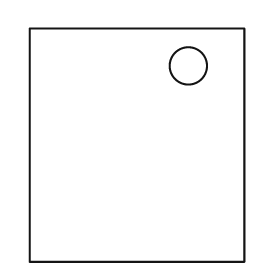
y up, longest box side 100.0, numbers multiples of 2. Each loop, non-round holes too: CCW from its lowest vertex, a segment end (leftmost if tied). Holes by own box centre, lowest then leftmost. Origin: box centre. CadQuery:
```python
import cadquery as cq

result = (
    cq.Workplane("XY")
    .moveTo(-46.0, -50.0)
    .lineTo(46.0, -50.0)
    .lineTo(46.0, 50.0)
    .lineTo(-46.0, 50.0)
    .close()
    .moveTo(22.0, 34.0)
    .circle(8.0)
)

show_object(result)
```